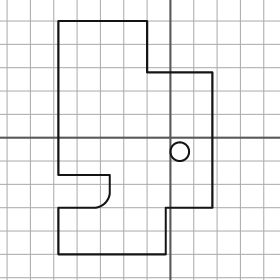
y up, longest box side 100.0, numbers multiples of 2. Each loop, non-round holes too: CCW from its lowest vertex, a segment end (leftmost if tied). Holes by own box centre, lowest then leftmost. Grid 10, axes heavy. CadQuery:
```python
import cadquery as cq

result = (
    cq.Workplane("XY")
    .moveTo(-48.0, -50.0)
    .lineTo(-2.0, -50.0)
    .lineTo(-2.0, -30.0)
    .lineTo(18.0, -30.0)
    .lineTo(18.0, 28.0)
    .lineTo(-10.0, 28.0)
    .lineTo(-10.0, 50.0)
    .lineTo(-48.0, 50.0)
    .lineTo(-48.0, -16.0)
    .lineTo(-26.0, -16.0)
    .lineTo(-26.0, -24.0)
    .threePointArc((-28.0, -28.0), (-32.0, -30.0))
    .lineTo(-48.0, -30.0)
    .close()
    .moveTo(4.0, -6.0)
    .circle(4.0)
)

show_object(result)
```